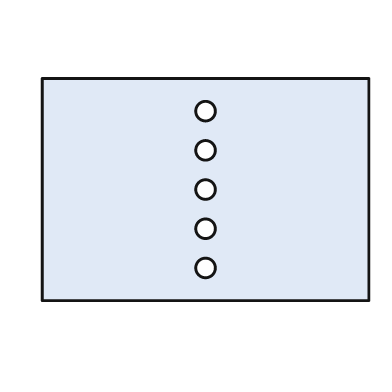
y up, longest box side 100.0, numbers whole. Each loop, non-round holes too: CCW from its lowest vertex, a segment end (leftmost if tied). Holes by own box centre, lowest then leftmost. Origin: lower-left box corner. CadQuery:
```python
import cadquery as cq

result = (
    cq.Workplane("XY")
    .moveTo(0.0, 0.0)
    .lineTo(100.0, 0.0)
    .lineTo(100.0, 68.0)
    .lineTo(0.0, 68.0)
    .close()
    .moveTo(50.0, 10.0)
    .circle(3.0)
    .moveTo(50.0, 22.0)
    .circle(3.0)
    .moveTo(50.0, 34.0)
    .circle(3.0)
    .moveTo(50.0, 46.0)
    .circle(3.0)
    .moveTo(50.0, 58.0)
    .circle(3.0)
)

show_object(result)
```